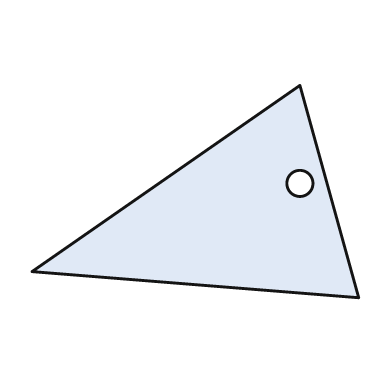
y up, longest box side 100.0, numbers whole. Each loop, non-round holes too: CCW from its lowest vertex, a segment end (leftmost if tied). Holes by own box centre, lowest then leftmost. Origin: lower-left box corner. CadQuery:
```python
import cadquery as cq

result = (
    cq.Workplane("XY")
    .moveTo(100.0, 0.0)
    .lineTo(82.0, 65.0)
    .lineTo(0.0, 8.0)
    .close()
    .moveTo(82.0, 35.0)
    .circle(4.0)
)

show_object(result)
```